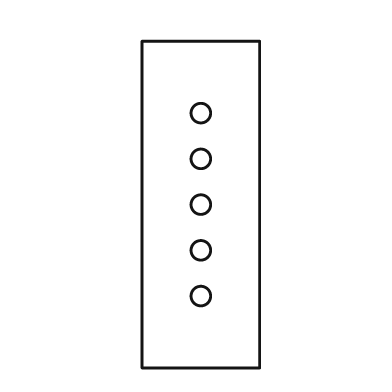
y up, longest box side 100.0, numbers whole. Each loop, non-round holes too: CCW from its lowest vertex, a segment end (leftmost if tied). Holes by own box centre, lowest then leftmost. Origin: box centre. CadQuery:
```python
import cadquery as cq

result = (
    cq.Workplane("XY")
    .moveTo(-18.0, -50.0)
    .lineTo(18.0, -50.0)
    .lineTo(18.0, 50.0)
    .lineTo(-18.0, 50.0)
    .close()
    .moveTo(0.0, -28.0)
    .circle(3.0)
    .moveTo(0.0, -14.0)
    .circle(3.0)
    .moveTo(0.0, 0.0)
    .circle(3.0)
    .moveTo(0.0, 14.0)
    .circle(3.0)
    .moveTo(0.0, 28.0)
    .circle(3.0)
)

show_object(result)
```